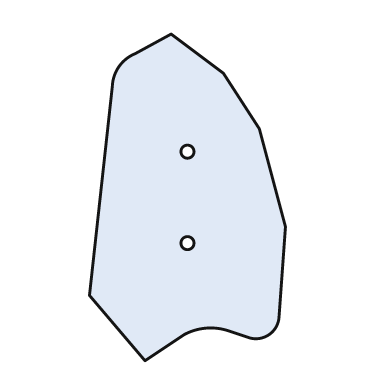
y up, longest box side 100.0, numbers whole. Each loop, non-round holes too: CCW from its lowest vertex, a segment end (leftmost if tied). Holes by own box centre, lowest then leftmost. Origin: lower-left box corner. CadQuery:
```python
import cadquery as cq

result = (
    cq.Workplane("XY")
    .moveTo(17.0, 0.0)
    .lineTo(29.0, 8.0)
    .threePointArc((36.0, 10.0), (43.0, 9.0))
    .lineTo(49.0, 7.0)
    .threePointArc((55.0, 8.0), (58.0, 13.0))
    .lineTo(60.0, 41.0)
    .lineTo(52.0, 71.0)
    .lineTo(41.0, 88.0)
    .lineTo(25.0, 100.0)
    .lineTo(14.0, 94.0)
    .threePointArc((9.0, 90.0), (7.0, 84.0))
    .lineTo(0.0, 20.0)
    .close()
    .moveTo(30.0, 36.0)
    .circle(2.0)
    .moveTo(30.0, 64.0)
    .circle(2.0)
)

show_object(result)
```